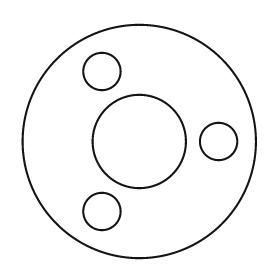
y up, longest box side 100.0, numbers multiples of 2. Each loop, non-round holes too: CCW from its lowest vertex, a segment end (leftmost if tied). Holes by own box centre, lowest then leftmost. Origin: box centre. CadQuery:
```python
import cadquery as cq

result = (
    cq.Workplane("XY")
    .moveTo(0.0, 0.0)
    .circle(50.0)
    .moveTo(-16.0, -30.0)
    .circle(8.0)
    .moveTo(0.0, 0.0)
    .circle(20.0)
    .moveTo(34.0, 0.0)
    .circle(8.0)
    .moveTo(-16.0, 30.0)
    .circle(8.0)
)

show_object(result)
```